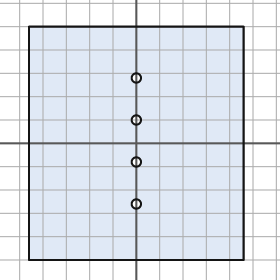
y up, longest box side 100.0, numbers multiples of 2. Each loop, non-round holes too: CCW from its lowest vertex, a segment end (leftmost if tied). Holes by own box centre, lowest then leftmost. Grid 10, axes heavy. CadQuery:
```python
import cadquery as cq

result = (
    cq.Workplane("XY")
    .moveTo(-46.0, -50.0)
    .lineTo(46.0, -50.0)
    .lineTo(46.0, 50.0)
    .lineTo(-46.0, 50.0)
    .close()
    .moveTo(0.0, -26.0)
    .circle(2.0)
    .moveTo(0.0, -8.0)
    .circle(2.0)
    .moveTo(0.0, 10.0)
    .circle(2.0)
    .moveTo(0.0, 28.0)
    .circle(2.0)
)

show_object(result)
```